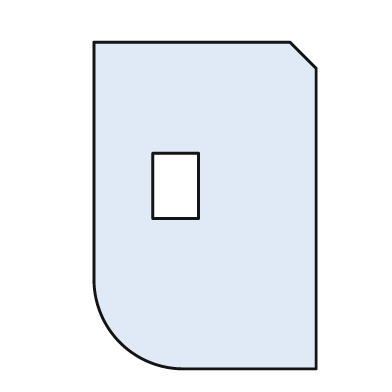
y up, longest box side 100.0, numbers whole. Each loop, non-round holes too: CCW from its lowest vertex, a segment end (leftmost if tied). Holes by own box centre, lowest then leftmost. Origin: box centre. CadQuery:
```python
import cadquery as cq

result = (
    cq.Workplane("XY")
    .moveTo(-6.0, -50.0)
    .lineTo(34.0, -50.0)
    .lineTo(34.0, 42.0)
    .lineTo(26.0, 50.0)
    .lineTo(-34.0, 50.0)
    .lineTo(-34.0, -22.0)
    .threePointArc((-26.0, -42.0), (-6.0, -50.0))
    .close()
    .moveTo(-16.0, -4.0)
    .lineTo(-2.0, -4.0)
    .lineTo(-2.0, 16.0)
    .lineTo(-16.0, 16.0)
    .close()
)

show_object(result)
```